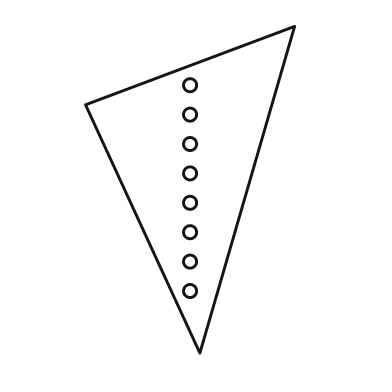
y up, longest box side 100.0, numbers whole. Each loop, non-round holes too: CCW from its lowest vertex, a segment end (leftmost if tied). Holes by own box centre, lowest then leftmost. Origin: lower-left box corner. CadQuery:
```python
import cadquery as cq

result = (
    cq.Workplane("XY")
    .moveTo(35.0, 0.0)
    .lineTo(64.0, 100.0)
    .lineTo(0.0, 76.0)
    .close()
    .moveTo(32.0, 19.0)
    .circle(2.0)
    .moveTo(32.0, 28.0)
    .circle(2.0)
    .moveTo(32.0, 37.0)
    .circle(2.0)
    .moveTo(32.0, 46.0)
    .circle(2.0)
    .moveTo(32.0, 55.0)
    .circle(2.0)
    .moveTo(32.0, 64.0)
    .circle(2.0)
    .moveTo(32.0, 73.0)
    .circle(2.0)
    .moveTo(32.0, 82.0)
    .circle(2.0)
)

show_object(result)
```